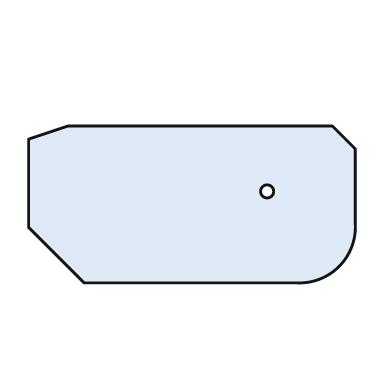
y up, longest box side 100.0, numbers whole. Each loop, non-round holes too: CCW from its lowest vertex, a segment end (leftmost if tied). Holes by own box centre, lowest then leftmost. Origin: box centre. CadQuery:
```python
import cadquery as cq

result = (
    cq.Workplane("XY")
    .moveTo(-33.0, -24.0)
    .lineTo(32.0, -24.0)
    .threePointArc((45.0, -19.0), (50.0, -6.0))
    .lineTo(50.0, 17.0)
    .lineTo(43.0, 24.0)
    .lineTo(-38.0, 24.0)
    .lineTo(-50.0, 20.0)
    .lineTo(-50.0, -7.0)
    .close()
    .moveTo(23.0, 4.0)
    .circle(2.0)
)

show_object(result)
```